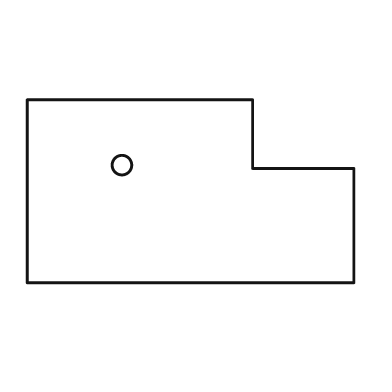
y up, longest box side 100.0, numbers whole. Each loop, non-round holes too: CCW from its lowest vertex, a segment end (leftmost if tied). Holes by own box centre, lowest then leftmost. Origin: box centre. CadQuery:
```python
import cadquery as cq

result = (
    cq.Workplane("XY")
    .moveTo(-50.0, -28.0)
    .lineTo(50.0, -28.0)
    .lineTo(50.0, 7.0)
    .lineTo(19.0, 7.0)
    .lineTo(19.0, 28.0)
    .lineTo(-50.0, 28.0)
    .close()
    .moveTo(-21.0, 8.0)
    .circle(3.0)
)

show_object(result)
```